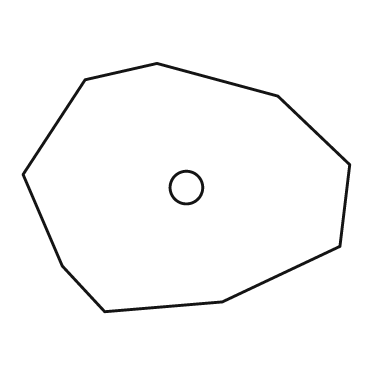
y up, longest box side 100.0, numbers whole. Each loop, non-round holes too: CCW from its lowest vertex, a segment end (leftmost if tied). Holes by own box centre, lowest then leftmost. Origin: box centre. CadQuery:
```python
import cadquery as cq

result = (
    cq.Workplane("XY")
    .moveTo(-25.0, -38.0)
    .lineTo(11.0, -35.0)
    .lineTo(47.0, -18.0)
    .lineTo(50.0, 7.0)
    .lineTo(28.0, 28.0)
    .lineTo(-9.0, 38.0)
    .lineTo(-31.0, 33.0)
    .lineTo(-50.0, 4.0)
    .lineTo(-38.0, -24.0)
    .close()
    .moveTo(0.0, 0.0)
    .circle(5.0)
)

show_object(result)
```